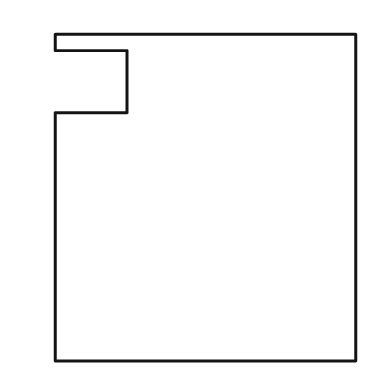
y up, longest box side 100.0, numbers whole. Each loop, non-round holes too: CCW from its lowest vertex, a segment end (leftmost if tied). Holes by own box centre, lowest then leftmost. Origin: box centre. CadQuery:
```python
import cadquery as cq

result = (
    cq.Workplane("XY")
    .moveTo(-46.0, -50.0)
    .lineTo(46.0, -50.0)
    .lineTo(46.0, 50.0)
    .lineTo(-46.0, 50.0)
    .lineTo(-46.0, 45.0)
    .lineTo(-24.0, 45.0)
    .lineTo(-24.0, 26.0)
    .lineTo(-46.0, 26.0)
    .close()
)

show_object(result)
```